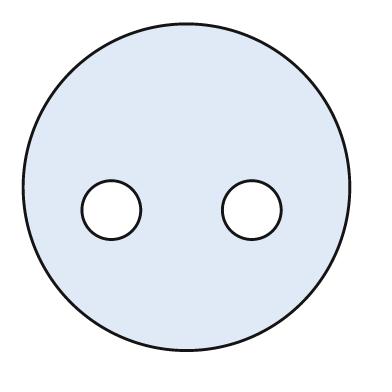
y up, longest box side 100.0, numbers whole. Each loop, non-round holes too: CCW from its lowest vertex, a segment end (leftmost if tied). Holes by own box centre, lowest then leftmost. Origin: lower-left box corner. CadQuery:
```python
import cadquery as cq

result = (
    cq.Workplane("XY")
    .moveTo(50.0, 50.0)
    .circle(50.0)
    .moveTo(27.0, 43.0)
    .circle(9.0)
    .moveTo(70.0, 43.0)
    .circle(9.0)
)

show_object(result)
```